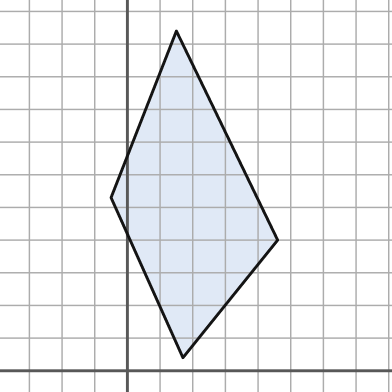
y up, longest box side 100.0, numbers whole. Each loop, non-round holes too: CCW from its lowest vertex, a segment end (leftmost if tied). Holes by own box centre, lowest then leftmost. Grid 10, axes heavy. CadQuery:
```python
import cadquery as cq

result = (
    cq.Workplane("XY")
    .moveTo(17.0, 4.0)
    .lineTo(46.0, 40.0)
    .lineTo(15.0, 104.0)
    .lineTo(-5.0, 53.0)
    .close()
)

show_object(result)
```